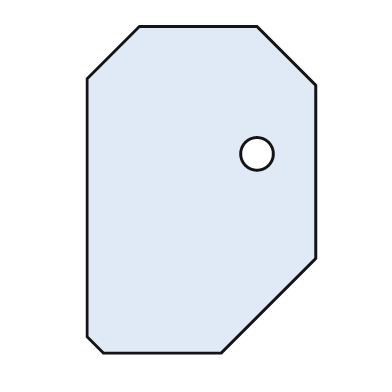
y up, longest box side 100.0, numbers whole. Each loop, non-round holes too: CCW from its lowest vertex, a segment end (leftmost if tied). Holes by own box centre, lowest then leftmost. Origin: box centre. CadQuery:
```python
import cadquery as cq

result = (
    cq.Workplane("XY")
    .moveTo(-30.0, -50.0)
    .lineTo(6.0, -50.0)
    .lineTo(35.0, -21.0)
    .lineTo(35.0, 32.0)
    .lineTo(17.0, 50.0)
    .lineTo(-19.0, 50.0)
    .lineTo(-35.0, 34.0)
    .lineTo(-35.0, -45.0)
    .close()
    .moveTo(17.0, 11.0)
    .circle(5.0)
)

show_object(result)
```